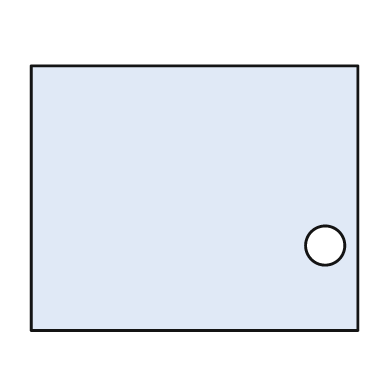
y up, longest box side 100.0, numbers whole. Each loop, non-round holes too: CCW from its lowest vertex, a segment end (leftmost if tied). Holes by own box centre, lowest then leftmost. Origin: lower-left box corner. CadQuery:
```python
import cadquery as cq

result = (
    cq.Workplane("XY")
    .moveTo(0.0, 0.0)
    .lineTo(100.0, 0.0)
    .lineTo(100.0, 81.0)
    .lineTo(0.0, 81.0)
    .close()
    .moveTo(90.0, 26.0)
    .circle(6.0)
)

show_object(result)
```